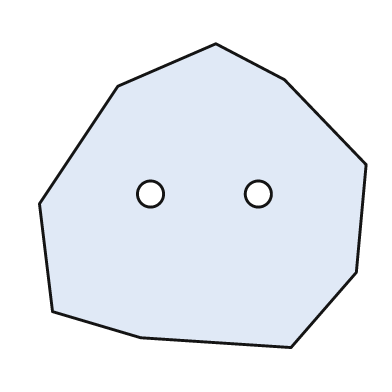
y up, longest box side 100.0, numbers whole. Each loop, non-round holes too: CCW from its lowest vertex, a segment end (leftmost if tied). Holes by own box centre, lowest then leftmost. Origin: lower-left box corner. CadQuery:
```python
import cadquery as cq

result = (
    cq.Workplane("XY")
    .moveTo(77.0, 0.0)
    .lineTo(97.0, 23.0)
    .lineTo(100.0, 56.0)
    .lineTo(75.0, 82.0)
    .lineTo(54.0, 93.0)
    .lineTo(24.0, 80.0)
    .lineTo(0.0, 44.0)
    .lineTo(4.0, 11.0)
    .lineTo(31.0, 3.0)
    .close()
    .moveTo(34.0, 47.0)
    .circle(4.0)
    .moveTo(67.0, 47.0)
    .circle(4.0)
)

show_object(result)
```